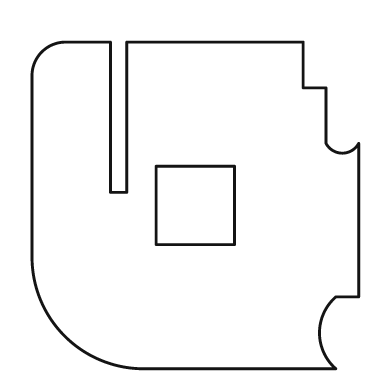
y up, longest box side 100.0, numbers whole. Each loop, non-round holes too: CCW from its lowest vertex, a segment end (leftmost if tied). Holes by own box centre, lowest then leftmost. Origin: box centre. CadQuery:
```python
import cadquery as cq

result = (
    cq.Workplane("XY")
    .moveTo(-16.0, -50.0)
    .lineTo(43.0, -50.0)
    .threePointArc((38.0, -39.0), (43.0, -28.0))
    .lineTo(50.0, -28.0)
    .lineTo(50.0, 19.0)
    .threePointArc((45.0, 16.0), (40.0, 19.0))
    .lineTo(40.0, 36.0)
    .lineTo(33.0, 36.0)
    .lineTo(33.0, 50.0)
    .lineTo(-21.0, 50.0)
    .lineTo(-21.0, 4.0)
    .lineTo(-26.0, 4.0)
    .lineTo(-26.0, 50.0)
    .lineTo(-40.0, 50.0)
    .threePointArc((-47.0, 47.0), (-50.0, 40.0))
    .lineTo(-50.0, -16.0)
    .threePointArc((-40.0, -40.0), (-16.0, -50.0))
    .close()
    .moveTo(-12.0, -12.0)
    .lineTo(12.0, -12.0)
    .lineTo(12.0, 12.0)
    .lineTo(-12.0, 12.0)
    .close()
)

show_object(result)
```